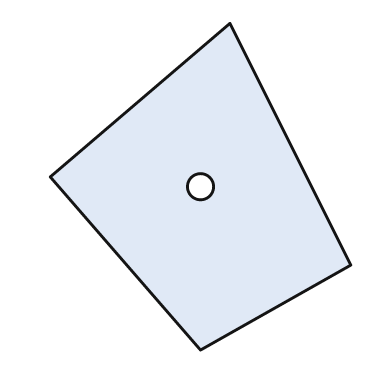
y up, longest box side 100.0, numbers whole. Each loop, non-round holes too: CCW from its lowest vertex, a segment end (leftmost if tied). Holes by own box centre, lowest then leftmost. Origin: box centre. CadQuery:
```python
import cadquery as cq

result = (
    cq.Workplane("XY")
    .moveTo(0.0, -50.0)
    .lineTo(46.0, -24.0)
    .lineTo(9.0, 50.0)
    .lineTo(-46.0, 3.0)
    .close()
    .moveTo(0.0, 0.0)
    .circle(4.0)
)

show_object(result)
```